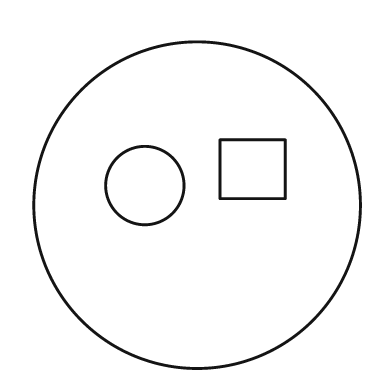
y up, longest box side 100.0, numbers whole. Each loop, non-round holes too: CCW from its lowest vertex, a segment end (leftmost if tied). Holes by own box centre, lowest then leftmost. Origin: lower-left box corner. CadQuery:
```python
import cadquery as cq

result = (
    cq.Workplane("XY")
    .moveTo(50.0, 50.0)
    .circle(50.0)
    .moveTo(34.0, 56.0)
    .circle(12.0)
    .moveTo(57.0, 52.0)
    .lineTo(77.0, 52.0)
    .lineTo(77.0, 70.0)
    .lineTo(57.0, 70.0)
    .close()
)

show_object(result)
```